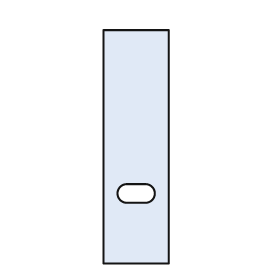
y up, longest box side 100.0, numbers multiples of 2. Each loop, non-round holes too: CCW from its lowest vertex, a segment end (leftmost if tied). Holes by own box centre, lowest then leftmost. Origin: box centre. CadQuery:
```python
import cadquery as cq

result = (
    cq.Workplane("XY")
    .moveTo(-14.0, -50.0)
    .lineTo(14.0, -50.0)
    .lineTo(14.0, 50.0)
    .lineTo(-14.0, 50.0)
    .close()
    .moveTo(-4.0, -24.0)
    .lineTo(4.0, -24.0)
    .threePointArc((8.0, -20.0), (4.0, -16.0))
    .lineTo(-4.0, -16.0)
    .threePointArc((-8.0, -20.0), (-4.0, -24.0))
    .close()
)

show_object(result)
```